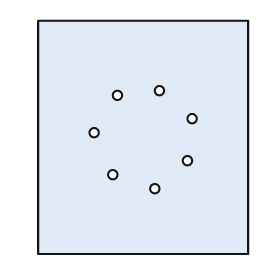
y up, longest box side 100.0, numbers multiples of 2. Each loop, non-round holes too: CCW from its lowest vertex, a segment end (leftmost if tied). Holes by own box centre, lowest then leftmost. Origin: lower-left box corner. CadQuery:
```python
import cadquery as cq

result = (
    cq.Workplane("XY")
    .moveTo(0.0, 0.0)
    .lineTo(90.0, 0.0)
    .lineTo(90.0, 100.0)
    .lineTo(0.0, 100.0)
    .close()
    .moveTo(50.0, 28.0)
    .circle(2.0)
    .moveTo(32.0, 34.0)
    .circle(2.0)
    .moveTo(64.0, 40.0)
    .circle(2.0)
    .moveTo(24.0, 52.0)
    .circle(2.0)
    .moveTo(66.0, 58.0)
    .circle(2.0)
    .moveTo(34.0, 68.0)
    .circle(2.0)
    .moveTo(52.0, 70.0)
    .circle(2.0)
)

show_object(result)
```